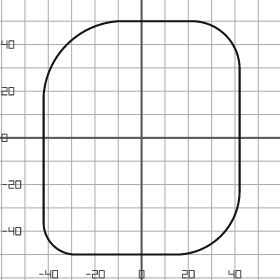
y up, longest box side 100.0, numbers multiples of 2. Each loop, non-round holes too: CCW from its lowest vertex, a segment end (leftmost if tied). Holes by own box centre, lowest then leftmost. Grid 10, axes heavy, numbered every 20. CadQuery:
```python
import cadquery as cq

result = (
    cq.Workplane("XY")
    .moveTo(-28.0, -50.0)
    .lineTo(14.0, -50.0)
    .threePointArc((34.0, -42.0), (42.0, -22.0))
    .lineTo(42.0, 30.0)
    .threePointArc((36.0, 44.0), (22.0, 50.0))
    .lineTo(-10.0, 50.0)
    .threePointArc((-32.0, 40.0), (-42.0, 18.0))
    .lineTo(-42.0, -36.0)
    .threePointArc((-38.0, -46.0), (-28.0, -50.0))
    .close()
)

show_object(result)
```